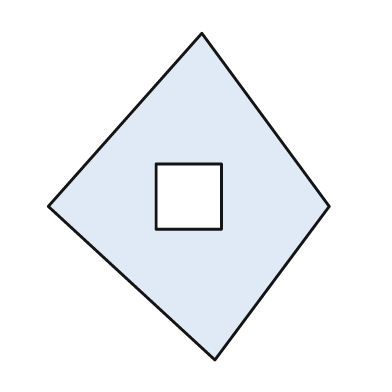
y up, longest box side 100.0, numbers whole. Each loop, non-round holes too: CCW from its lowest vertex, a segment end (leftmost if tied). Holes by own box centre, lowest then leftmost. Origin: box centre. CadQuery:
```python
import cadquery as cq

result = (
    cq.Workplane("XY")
    .moveTo(8.0, -50.0)
    .lineTo(43.0, -3.0)
    .lineTo(4.0, 50.0)
    .lineTo(-43.0, -3.0)
    .close()
    .moveTo(-10.0, -10.0)
    .lineTo(10.0, -10.0)
    .lineTo(10.0, 10.0)
    .lineTo(-10.0, 10.0)
    .close()
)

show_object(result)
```